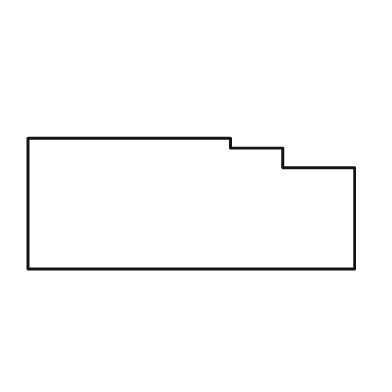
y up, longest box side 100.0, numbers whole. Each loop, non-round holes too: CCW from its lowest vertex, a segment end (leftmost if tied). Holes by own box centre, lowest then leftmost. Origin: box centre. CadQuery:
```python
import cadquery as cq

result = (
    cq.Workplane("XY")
    .moveTo(-50.0, -20.0)
    .lineTo(50.0, -20.0)
    .lineTo(50.0, 11.0)
    .lineTo(28.0, 11.0)
    .lineTo(28.0, 17.0)
    .lineTo(12.0, 17.0)
    .lineTo(12.0, 20.0)
    .lineTo(-50.0, 20.0)
    .close()
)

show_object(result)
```